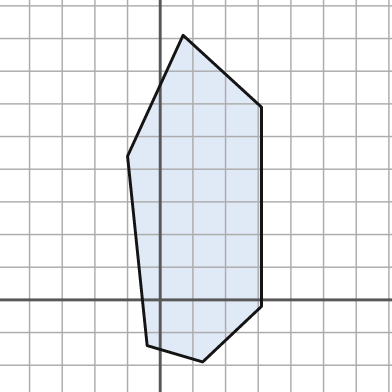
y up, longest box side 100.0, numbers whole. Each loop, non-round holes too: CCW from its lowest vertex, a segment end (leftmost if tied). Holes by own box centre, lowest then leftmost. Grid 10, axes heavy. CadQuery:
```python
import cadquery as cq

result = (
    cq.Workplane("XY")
    .moveTo(13.0, -19.0)
    .lineTo(31.0, -2.0)
    .lineTo(31.0, 59.0)
    .lineTo(7.0, 81.0)
    .lineTo(-10.0, 44.0)
    .lineTo(-4.0, -14.0)
    .close()
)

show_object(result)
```